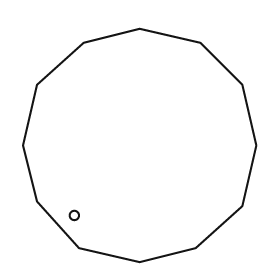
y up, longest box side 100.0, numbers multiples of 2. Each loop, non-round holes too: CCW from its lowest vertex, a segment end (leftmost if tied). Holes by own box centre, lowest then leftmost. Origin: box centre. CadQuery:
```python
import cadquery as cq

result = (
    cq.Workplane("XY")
    .moveTo(0.0, -50.0)
    .lineTo(24.0, -44.0)
    .lineTo(44.0, -26.0)
    .lineTo(50.0, 0.0)
    .lineTo(44.0, 26.0)
    .lineTo(26.0, 44.0)
    .lineTo(0.0, 50.0)
    .lineTo(-24.0, 44.0)
    .lineTo(-44.0, 26.0)
    .lineTo(-50.0, 0.0)
    .lineTo(-44.0, -24.0)
    .lineTo(-26.0, -44.0)
    .close()
    .moveTo(-28.0, -30.0)
    .circle(2.0)
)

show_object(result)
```